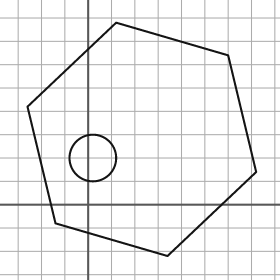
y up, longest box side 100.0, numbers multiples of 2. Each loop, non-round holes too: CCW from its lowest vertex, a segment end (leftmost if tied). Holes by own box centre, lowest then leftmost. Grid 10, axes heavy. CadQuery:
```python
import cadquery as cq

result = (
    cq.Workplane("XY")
    .moveTo(34.0, -22.0)
    .lineTo(72.0, 14.0)
    .lineTo(60.0, 64.0)
    .lineTo(12.0, 78.0)
    .lineTo(-26.0, 42.0)
    .lineTo(-14.0, -8.0)
    .close()
    .moveTo(2.0, 20.0)
    .circle(10.0)
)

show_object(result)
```